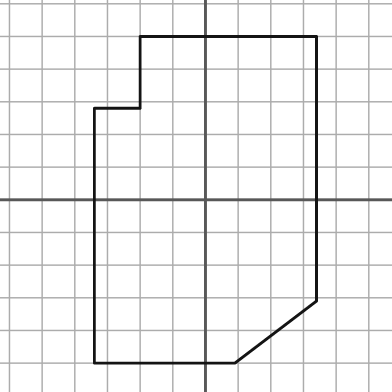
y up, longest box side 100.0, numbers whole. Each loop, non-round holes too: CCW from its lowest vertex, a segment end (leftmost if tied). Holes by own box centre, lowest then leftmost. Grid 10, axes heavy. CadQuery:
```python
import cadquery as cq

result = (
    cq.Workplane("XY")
    .moveTo(-34.0, -50.0)
    .lineTo(9.0, -50.0)
    .lineTo(34.0, -31.0)
    .lineTo(34.0, 50.0)
    .lineTo(-20.0, 50.0)
    .lineTo(-20.0, 28.0)
    .lineTo(-34.0, 28.0)
    .close()
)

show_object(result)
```